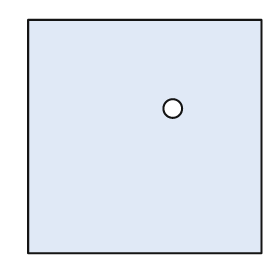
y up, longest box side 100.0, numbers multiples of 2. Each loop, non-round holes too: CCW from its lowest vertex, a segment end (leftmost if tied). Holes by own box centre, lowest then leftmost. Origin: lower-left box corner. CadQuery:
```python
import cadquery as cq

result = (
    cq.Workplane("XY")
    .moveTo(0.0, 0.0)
    .lineTo(100.0, 0.0)
    .lineTo(100.0, 100.0)
    .lineTo(0.0, 100.0)
    .close()
    .moveTo(62.0, 62.0)
    .circle(4.0)
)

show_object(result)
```